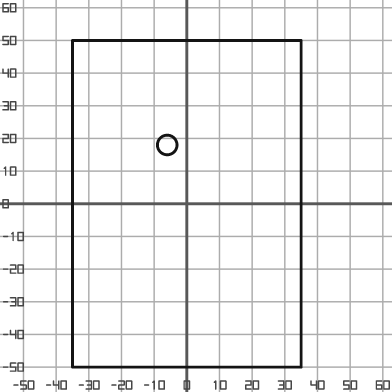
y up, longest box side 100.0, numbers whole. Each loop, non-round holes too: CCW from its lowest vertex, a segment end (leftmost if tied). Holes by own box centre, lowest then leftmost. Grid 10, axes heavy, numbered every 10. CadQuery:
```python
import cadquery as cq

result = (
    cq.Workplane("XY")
    .moveTo(-35.0, -50.0)
    .lineTo(35.0, -50.0)
    .lineTo(35.0, 50.0)
    .lineTo(-35.0, 50.0)
    .close()
    .moveTo(-6.0, 18.0)
    .circle(3.0)
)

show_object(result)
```